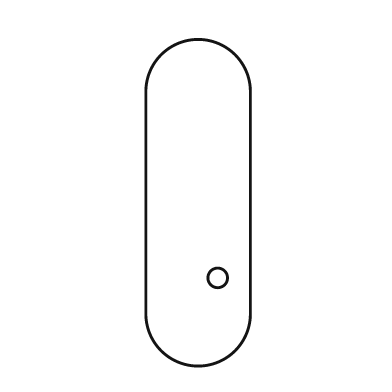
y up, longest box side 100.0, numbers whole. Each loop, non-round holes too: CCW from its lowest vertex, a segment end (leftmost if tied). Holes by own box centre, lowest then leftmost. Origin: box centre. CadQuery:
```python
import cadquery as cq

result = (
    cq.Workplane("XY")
    .moveTo(-16.0, -34.0)
    .threePointArc((0.0, -50.0), (16.0, -34.0))
    .lineTo(16.0, 34.0)
    .threePointArc((0.0, 50.0), (-16.0, 34.0))
    .close()
    .moveTo(6.0, -23.0)
    .circle(3.0)
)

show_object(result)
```